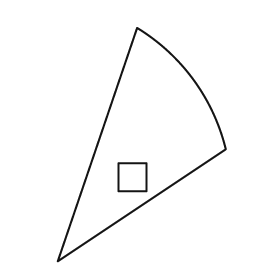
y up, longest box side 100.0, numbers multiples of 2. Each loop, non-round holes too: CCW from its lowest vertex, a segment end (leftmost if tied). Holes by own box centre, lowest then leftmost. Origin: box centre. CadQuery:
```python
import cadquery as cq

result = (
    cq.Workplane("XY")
    .moveTo(-36.0, -50.0)
    .lineTo(36.0, -2.0)
    .threePointArc((22.0, 28.0), (-2.0, 50.0))
    .close()
    .moveTo(-10.0, -20.0)
    .lineTo(2.0, -20.0)
    .lineTo(2.0, -8.0)
    .lineTo(-10.0, -8.0)
    .close()
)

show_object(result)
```